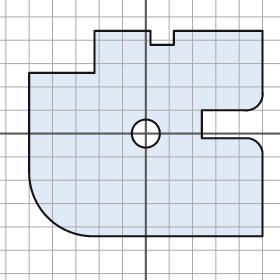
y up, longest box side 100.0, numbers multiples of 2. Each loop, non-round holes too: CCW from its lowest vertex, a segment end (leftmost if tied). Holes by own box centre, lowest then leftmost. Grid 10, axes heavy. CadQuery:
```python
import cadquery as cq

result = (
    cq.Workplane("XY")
    .moveTo(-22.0, -44.0)
    .lineTo(50.0, -44.0)
    .lineTo(50.0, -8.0)
    .threePointArc((48.0, -4.0), (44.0, -2.0))
    .lineTo(24.0, -2.0)
    .lineTo(24.0, 10.0)
    .lineTo(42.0, 10.0)
    .threePointArc((48.0, 12.0), (50.0, 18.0))
    .lineTo(50.0, 44.0)
    .lineTo(12.0, 44.0)
    .lineTo(12.0, 38.0)
    .lineTo(2.0, 38.0)
    .lineTo(2.0, 44.0)
    .lineTo(-22.0, 44.0)
    .lineTo(-22.0, 26.0)
    .lineTo(-50.0, 26.0)
    .lineTo(-50.0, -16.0)
    .threePointArc((-42.0, -36.0), (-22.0, -44.0))
    .close()
    .moveTo(0.0, 0.0)
    .circle(6.0)
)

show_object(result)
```